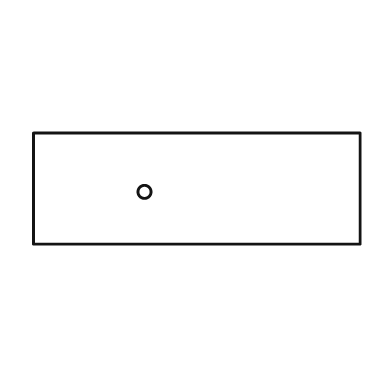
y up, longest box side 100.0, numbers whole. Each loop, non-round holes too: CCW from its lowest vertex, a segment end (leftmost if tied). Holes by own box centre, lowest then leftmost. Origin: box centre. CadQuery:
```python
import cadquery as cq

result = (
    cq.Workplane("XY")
    .moveTo(-50.0, -17.0)
    .lineTo(50.0, -17.0)
    .lineTo(50.0, 17.0)
    .lineTo(-50.0, 17.0)
    .close()
    .moveTo(-16.0, -1.0)
    .circle(2.0)
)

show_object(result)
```